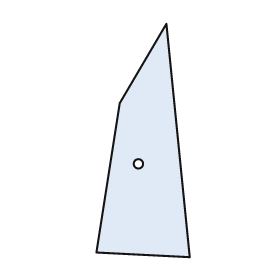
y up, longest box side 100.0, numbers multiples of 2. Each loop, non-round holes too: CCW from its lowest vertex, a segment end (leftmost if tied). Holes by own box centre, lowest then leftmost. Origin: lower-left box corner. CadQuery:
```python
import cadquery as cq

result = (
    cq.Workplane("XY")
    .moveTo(40.0, 0.0)
    .lineTo(30.0, 100.0)
    .lineTo(10.0, 66.0)
    .lineTo(0.0, 2.0)
    .close()
    .moveTo(18.0, 40.0)
    .circle(2.0)
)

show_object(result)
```